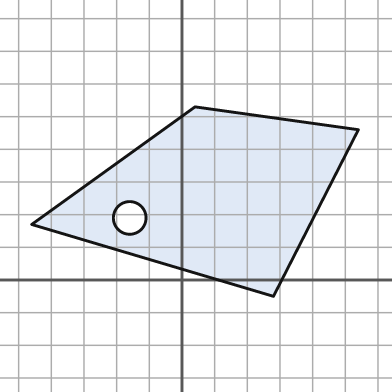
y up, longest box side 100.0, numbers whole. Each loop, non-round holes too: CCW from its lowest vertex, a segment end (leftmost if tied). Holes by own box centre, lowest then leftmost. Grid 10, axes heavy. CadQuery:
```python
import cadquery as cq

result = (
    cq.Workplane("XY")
    .moveTo(28.0, -5.0)
    .lineTo(54.0, 46.0)
    .lineTo(4.0, 53.0)
    .lineTo(-46.0, 17.0)
    .close()
    .moveTo(-16.0, 19.0)
    .circle(5.0)
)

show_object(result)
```